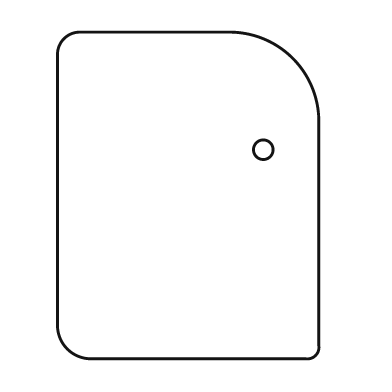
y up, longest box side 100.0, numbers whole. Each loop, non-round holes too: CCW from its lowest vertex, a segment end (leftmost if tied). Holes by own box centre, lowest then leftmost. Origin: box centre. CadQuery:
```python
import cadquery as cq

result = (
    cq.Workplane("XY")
    .moveTo(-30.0, -50.0)
    .lineTo(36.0, -50.0)
    .threePointArc((39.0, -49.0), (40.0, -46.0))
    .lineTo(40.0, 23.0)
    .threePointArc((32.0, 42.0), (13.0, 50.0))
    .lineTo(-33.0, 50.0)
    .threePointArc((-38.0, 48.0), (-40.0, 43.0))
    .lineTo(-40.0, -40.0)
    .threePointArc((-37.0, -47.0), (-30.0, -50.0))
    .close()
    .moveTo(23.0, 14.0)
    .circle(3.0)
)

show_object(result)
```